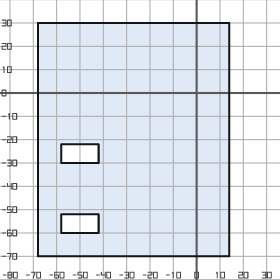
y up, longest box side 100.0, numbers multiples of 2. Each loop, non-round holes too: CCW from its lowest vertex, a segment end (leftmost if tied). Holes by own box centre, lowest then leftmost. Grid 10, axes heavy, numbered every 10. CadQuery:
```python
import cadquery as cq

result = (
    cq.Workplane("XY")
    .moveTo(-68.0, -70.0)
    .lineTo(14.0, -70.0)
    .lineTo(14.0, 30.0)
    .lineTo(-68.0, 30.0)
    .close()
    .moveTo(-58.0, -60.0)
    .lineTo(-42.0, -60.0)
    .lineTo(-42.0, -52.0)
    .lineTo(-58.0, -52.0)
    .close()
    .moveTo(-58.0, -30.0)
    .lineTo(-42.0, -30.0)
    .lineTo(-42.0, -22.0)
    .lineTo(-58.0, -22.0)
    .close()
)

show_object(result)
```